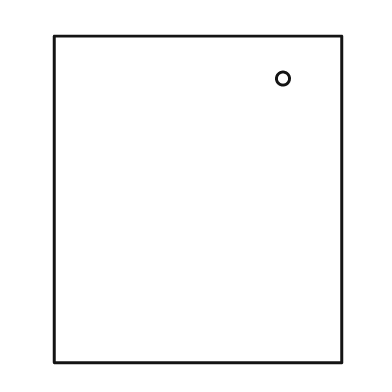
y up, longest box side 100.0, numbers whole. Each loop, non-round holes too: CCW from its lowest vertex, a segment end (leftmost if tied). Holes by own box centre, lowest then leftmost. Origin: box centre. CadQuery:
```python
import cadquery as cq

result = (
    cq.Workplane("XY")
    .moveTo(-44.0, -50.0)
    .lineTo(44.0, -50.0)
    .lineTo(44.0, 50.0)
    .lineTo(-44.0, 50.0)
    .close()
    .moveTo(26.0, 37.0)
    .circle(2.0)
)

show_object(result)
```